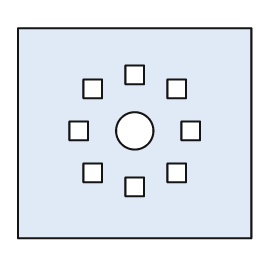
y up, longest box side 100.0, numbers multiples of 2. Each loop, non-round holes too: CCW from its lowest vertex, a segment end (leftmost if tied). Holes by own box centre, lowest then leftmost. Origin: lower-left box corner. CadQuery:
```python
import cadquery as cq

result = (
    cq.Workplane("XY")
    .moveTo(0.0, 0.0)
    .lineTo(100.0, 0.0)
    .lineTo(100.0, 90.0)
    .lineTo(0.0, 90.0)
    .close()
    .moveTo(46.0, 18.0)
    .lineTo(54.0, 18.0)
    .lineTo(54.0, 26.0)
    .lineTo(46.0, 26.0)
    .close()
    .moveTo(28.0, 24.0)
    .lineTo(36.0, 24.0)
    .lineTo(36.0, 32.0)
    .lineTo(28.0, 32.0)
    .close()
    .moveTo(64.0, 24.0)
    .lineTo(72.0, 24.0)
    .lineTo(72.0, 32.0)
    .lineTo(64.0, 32.0)
    .close()
    .moveTo(22.0, 42.0)
    .lineTo(30.0, 42.0)
    .lineTo(30.0, 50.0)
    .lineTo(22.0, 50.0)
    .close()
    .moveTo(50.0, 46.0)
    .circle(8.0)
    .moveTo(70.0, 42.0)
    .lineTo(78.0, 42.0)
    .lineTo(78.0, 50.0)
    .lineTo(70.0, 50.0)
    .close()
    .moveTo(28.0, 60.0)
    .lineTo(36.0, 60.0)
    .lineTo(36.0, 68.0)
    .lineTo(28.0, 68.0)
    .close()
    .moveTo(64.0, 60.0)
    .lineTo(72.0, 60.0)
    .lineTo(72.0, 68.0)
    .lineTo(64.0, 68.0)
    .close()
    .moveTo(46.0, 66.0)
    .lineTo(54.0, 66.0)
    .lineTo(54.0, 74.0)
    .lineTo(46.0, 74.0)
    .close()
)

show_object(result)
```